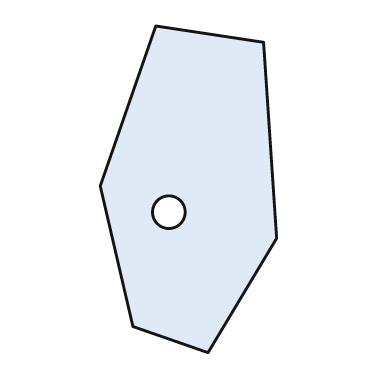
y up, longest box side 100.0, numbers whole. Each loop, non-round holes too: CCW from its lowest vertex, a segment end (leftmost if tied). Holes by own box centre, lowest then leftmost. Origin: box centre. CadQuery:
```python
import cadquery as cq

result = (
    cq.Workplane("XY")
    .moveTo(6.0, -50.0)
    .lineTo(27.0, -15.0)
    .lineTo(23.0, 45.0)
    .lineTo(-10.0, 50.0)
    .lineTo(-27.0, 1.0)
    .lineTo(-17.0, -42.0)
    .close()
    .moveTo(-6.0, -7.0)
    .circle(5.0)
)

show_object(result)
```